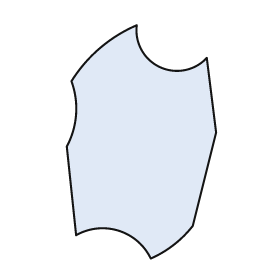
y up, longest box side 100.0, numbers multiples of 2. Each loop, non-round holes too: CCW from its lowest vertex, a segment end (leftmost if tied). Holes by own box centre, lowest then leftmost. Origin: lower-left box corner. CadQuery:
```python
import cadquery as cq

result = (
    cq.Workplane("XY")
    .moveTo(36.0, 0.0)
    .threePointArc((46.0, 6.0), (54.0, 14.0))
    .lineTo(64.0, 54.0)
    .lineTo(60.0, 86.0)
    .threePointArc((40.0, 82.0), (30.0, 100.0))
    .threePointArc((14.0, 90.0), (2.0, 76.0))
    .threePointArc((4.0, 62.0), (0.0, 48.0))
    .lineTo(4.0, 10.0)
    .threePointArc((22.0, 12.0), (36.0, 0.0))
    .close()
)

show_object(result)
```